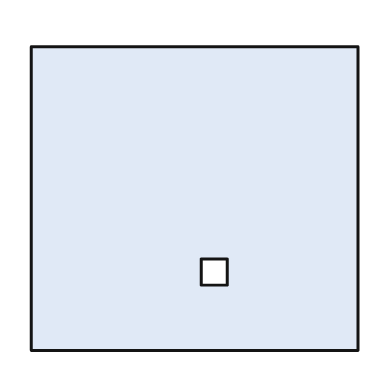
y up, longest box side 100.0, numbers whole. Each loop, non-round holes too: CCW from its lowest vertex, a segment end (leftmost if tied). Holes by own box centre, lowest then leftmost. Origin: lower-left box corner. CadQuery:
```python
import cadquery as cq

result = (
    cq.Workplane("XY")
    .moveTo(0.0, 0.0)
    .lineTo(100.0, 0.0)
    .lineTo(100.0, 93.0)
    .lineTo(0.0, 93.0)
    .close()
    .moveTo(52.0, 20.0)
    .lineTo(60.0, 20.0)
    .lineTo(60.0, 28.0)
    .lineTo(52.0, 28.0)
    .close()
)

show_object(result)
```